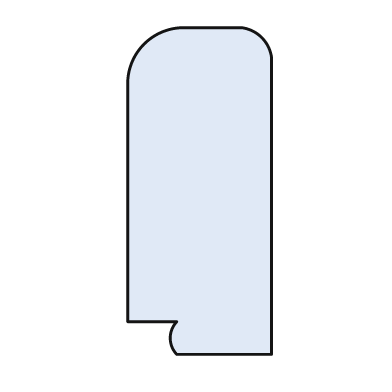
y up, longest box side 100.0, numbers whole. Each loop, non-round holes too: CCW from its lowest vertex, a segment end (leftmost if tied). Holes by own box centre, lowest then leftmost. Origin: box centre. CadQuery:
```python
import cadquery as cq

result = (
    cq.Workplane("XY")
    .moveTo(-7.0, -50.0)
    .lineTo(22.0, -50.0)
    .lineTo(22.0, 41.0)
    .threePointArc((19.0, 47.0), (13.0, 50.0))
    .lineTo(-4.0, 50.0)
    .threePointArc((-17.0, 45.0), (-22.0, 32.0))
    .lineTo(-22.0, -40.0)
    .lineTo(-7.0, -40.0)
    .threePointArc((-9.0, -45.0), (-7.0, -50.0))
    .close()
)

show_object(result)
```